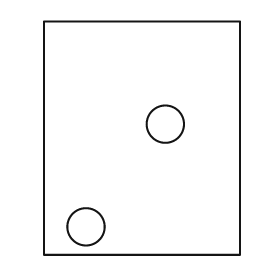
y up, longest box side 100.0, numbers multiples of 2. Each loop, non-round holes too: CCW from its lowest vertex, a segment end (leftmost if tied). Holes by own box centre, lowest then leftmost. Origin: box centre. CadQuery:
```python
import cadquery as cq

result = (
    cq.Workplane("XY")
    .moveTo(-42.0, -50.0)
    .lineTo(42.0, -50.0)
    .lineTo(42.0, 50.0)
    .lineTo(-42.0, 50.0)
    .close()
    .moveTo(-24.0, -38.0)
    .circle(8.0)
    .moveTo(10.0, 6.0)
    .circle(8.0)
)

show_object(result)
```